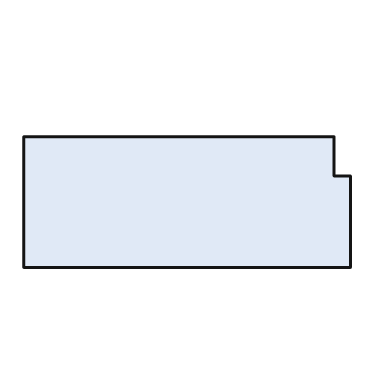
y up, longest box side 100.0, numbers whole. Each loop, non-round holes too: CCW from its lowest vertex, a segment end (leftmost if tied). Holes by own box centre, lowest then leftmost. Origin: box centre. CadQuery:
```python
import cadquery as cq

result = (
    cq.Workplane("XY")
    .moveTo(-50.0, -20.0)
    .lineTo(50.0, -20.0)
    .lineTo(50.0, 8.0)
    .lineTo(45.0, 8.0)
    .lineTo(45.0, 20.0)
    .lineTo(-50.0, 20.0)
    .close()
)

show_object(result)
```